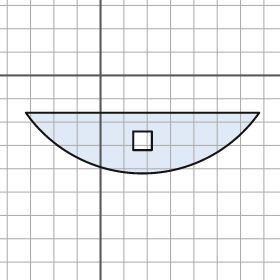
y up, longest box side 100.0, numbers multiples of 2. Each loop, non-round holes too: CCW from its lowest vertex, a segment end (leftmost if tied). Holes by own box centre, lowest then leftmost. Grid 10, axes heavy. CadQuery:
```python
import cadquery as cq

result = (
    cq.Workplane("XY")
    .moveTo(-32.0, -16.0)
    .threePointArc((18.0, -42.0), (68.0, -16.0))
    .close()
    .moveTo(14.0, -32.0)
    .lineTo(22.0, -32.0)
    .lineTo(22.0, -24.0)
    .lineTo(14.0, -24.0)
    .close()
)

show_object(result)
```